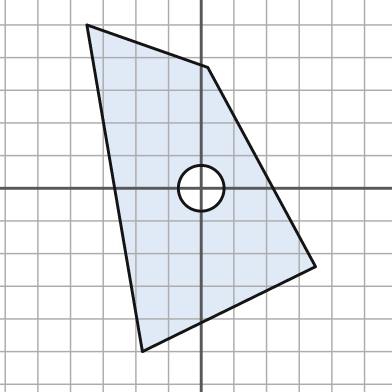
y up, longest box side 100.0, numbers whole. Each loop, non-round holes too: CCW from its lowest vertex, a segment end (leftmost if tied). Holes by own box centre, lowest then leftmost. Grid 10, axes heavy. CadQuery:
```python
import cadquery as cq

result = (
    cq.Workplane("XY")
    .moveTo(-18.0, -50.0)
    .lineTo(35.0, -24.0)
    .lineTo(2.0, 37.0)
    .lineTo(-35.0, 50.0)
    .close()
    .moveTo(0.0, 0.0)
    .circle(7.0)
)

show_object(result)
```